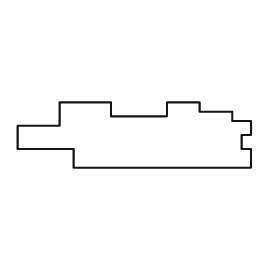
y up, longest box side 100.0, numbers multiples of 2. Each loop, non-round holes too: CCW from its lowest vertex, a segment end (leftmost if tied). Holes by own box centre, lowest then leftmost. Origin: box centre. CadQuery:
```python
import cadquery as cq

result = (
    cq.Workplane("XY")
    .moveTo(-26.0, -14.0)
    .lineTo(50.0, -14.0)
    .lineTo(50.0, -6.0)
    .lineTo(46.0, -6.0)
    .lineTo(46.0, 0.0)
    .lineTo(50.0, 0.0)
    .lineTo(50.0, 6.0)
    .lineTo(42.0, 6.0)
    .lineTo(42.0, 10.0)
    .lineTo(28.0, 10.0)
    .lineTo(28.0, 14.0)
    .lineTo(14.0, 14.0)
    .lineTo(14.0, 8.0)
    .lineTo(-10.0, 8.0)
    .lineTo(-10.0, 14.0)
    .lineTo(-32.0, 14.0)
    .lineTo(-32.0, 4.0)
    .lineTo(-50.0, 4.0)
    .lineTo(-50.0, -6.0)
    .lineTo(-26.0, -6.0)
    .close()
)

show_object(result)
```